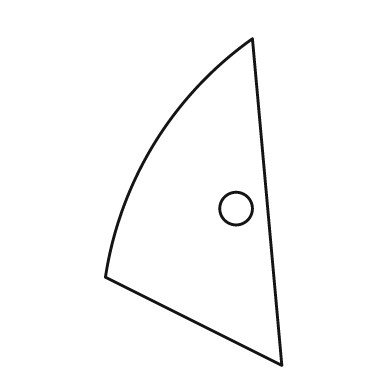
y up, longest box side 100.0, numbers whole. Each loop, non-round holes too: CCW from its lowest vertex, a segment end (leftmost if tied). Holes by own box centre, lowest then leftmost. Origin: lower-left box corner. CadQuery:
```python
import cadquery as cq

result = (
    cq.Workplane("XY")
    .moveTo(54.0, 0.0)
    .lineTo(45.0, 100.0)
    .threePointArc((15.0, 68.0), (0.0, 27.0))
    .close()
    .moveTo(40.0, 48.0)
    .circle(5.0)
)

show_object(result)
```